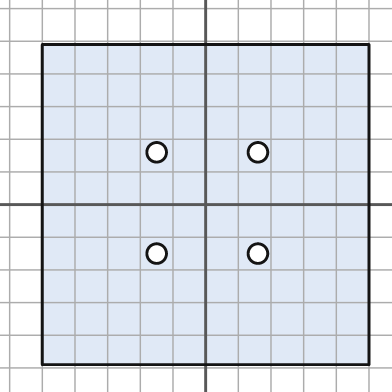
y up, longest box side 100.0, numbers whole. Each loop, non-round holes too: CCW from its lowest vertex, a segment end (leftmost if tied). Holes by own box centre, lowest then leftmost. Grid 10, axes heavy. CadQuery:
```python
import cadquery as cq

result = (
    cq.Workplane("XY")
    .moveTo(-50.0, -49.0)
    .lineTo(50.0, -49.0)
    .lineTo(50.0, 49.0)
    .lineTo(-50.0, 49.0)
    .close()
    .moveTo(-15.0, -15.0)
    .circle(3.0)
    .moveTo(16.0, -15.0)
    .circle(3.0)
    .moveTo(-15.0, 16.0)
    .circle(3.0)
    .moveTo(16.0, 16.0)
    .circle(3.0)
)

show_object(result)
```